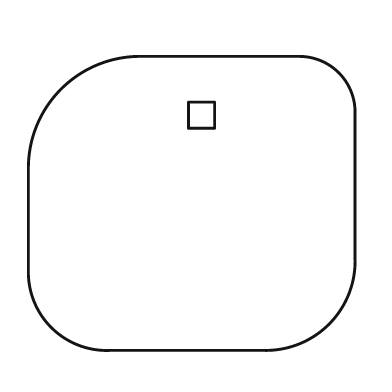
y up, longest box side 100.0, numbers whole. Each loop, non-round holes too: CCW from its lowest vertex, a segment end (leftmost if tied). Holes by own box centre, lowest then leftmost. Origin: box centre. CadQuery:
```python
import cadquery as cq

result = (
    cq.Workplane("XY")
    .moveTo(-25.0, -45.0)
    .lineTo(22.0, -45.0)
    .threePointArc((42.0, -37.0), (50.0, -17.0))
    .lineTo(50.0, 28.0)
    .threePointArc((45.0, 40.0), (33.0, 45.0))
    .lineTo(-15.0, 45.0)
    .threePointArc((-40.0, 35.0), (-50.0, 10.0))
    .lineTo(-50.0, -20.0)
    .threePointArc((-43.0, -38.0), (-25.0, -45.0))
    .close()
    .moveTo(-1.0, 23.0)
    .lineTo(7.0, 23.0)
    .lineTo(7.0, 31.0)
    .lineTo(-1.0, 31.0)
    .close()
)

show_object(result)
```